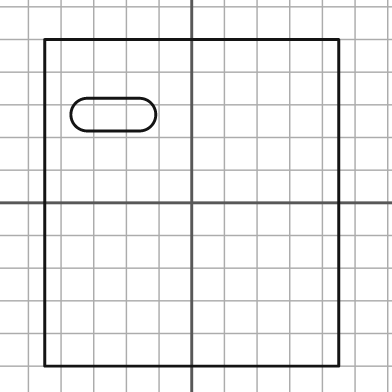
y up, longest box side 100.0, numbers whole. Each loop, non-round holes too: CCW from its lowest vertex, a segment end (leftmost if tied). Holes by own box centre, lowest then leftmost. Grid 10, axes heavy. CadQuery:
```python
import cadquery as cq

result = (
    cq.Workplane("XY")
    .moveTo(-45.0, -50.0)
    .lineTo(45.0, -50.0)
    .lineTo(45.0, 50.0)
    .lineTo(-45.0, 50.0)
    .close()
    .moveTo(-32.0, 22.0)
    .lineTo(-16.0, 22.0)
    .threePointArc((-11.0, 27.0), (-16.0, 32.0))
    .lineTo(-32.0, 32.0)
    .threePointArc((-37.0, 27.0), (-32.0, 22.0))
    .close()
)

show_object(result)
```